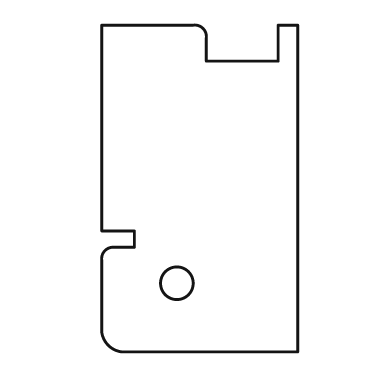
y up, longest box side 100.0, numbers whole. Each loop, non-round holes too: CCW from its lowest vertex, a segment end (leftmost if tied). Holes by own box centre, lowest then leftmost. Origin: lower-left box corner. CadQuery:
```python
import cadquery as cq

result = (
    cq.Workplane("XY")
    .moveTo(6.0, 0.0)
    .lineTo(60.0, 0.0)
    .lineTo(60.0, 100.0)
    .lineTo(54.0, 100.0)
    .lineTo(54.0, 89.0)
    .lineTo(32.0, 89.0)
    .lineTo(32.0, 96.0)
    .threePointArc((31.0, 99.0), (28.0, 100.0))
    .lineTo(0.0, 100.0)
    .lineTo(0.0, 37.0)
    .lineTo(10.0, 37.0)
    .lineTo(10.0, 32.0)
    .lineTo(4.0, 32.0)
    .threePointArc((1.0, 31.0), (0.0, 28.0))
    .lineTo(0.0, 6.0)
    .threePointArc((2.0, 2.0), (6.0, 0.0))
    .close()
    .moveTo(23.0, 21.0)
    .circle(5.0)
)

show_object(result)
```